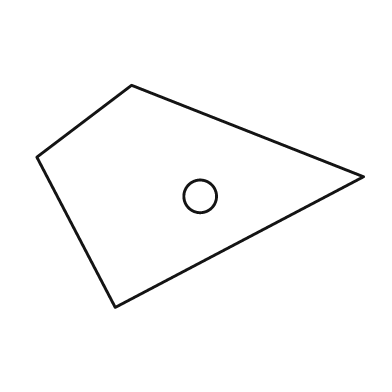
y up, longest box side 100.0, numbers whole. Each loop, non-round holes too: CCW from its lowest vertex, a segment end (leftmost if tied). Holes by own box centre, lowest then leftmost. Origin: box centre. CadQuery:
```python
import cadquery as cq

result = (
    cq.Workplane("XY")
    .moveTo(-26.0, -34.0)
    .lineTo(50.0, 6.0)
    .lineTo(-21.0, 34.0)
    .lineTo(-50.0, 12.0)
    .close()
    .moveTo(0.0, 0.0)
    .circle(5.0)
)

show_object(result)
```